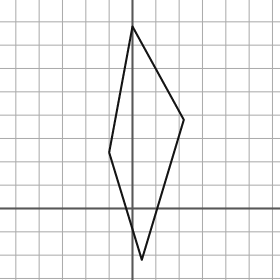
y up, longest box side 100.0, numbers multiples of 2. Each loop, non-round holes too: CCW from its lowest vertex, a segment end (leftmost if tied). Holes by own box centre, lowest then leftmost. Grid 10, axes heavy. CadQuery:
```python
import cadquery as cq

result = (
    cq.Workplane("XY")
    .moveTo(4.0, -22.0)
    .lineTo(22.0, 38.0)
    .lineTo(0.0, 78.0)
    .lineTo(-10.0, 24.0)
    .close()
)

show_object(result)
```